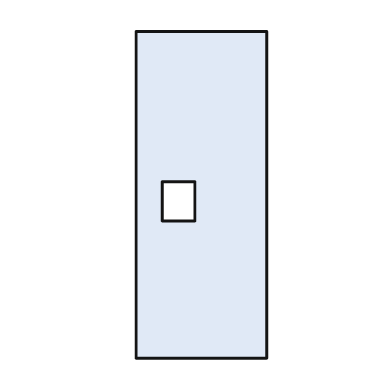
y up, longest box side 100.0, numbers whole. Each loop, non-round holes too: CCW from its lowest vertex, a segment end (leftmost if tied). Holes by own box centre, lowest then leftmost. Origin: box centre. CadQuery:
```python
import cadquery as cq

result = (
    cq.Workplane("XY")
    .moveTo(-20.0, -50.0)
    .lineTo(20.0, -50.0)
    .lineTo(20.0, 50.0)
    .lineTo(-20.0, 50.0)
    .close()
    .moveTo(-12.0, -8.0)
    .lineTo(-2.0, -8.0)
    .lineTo(-2.0, 4.0)
    .lineTo(-12.0, 4.0)
    .close()
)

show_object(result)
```